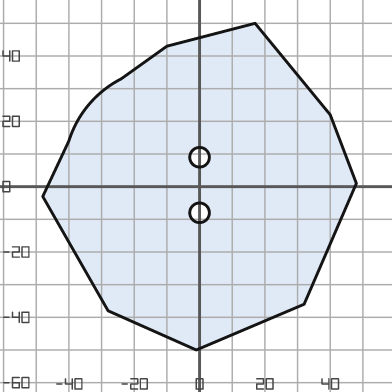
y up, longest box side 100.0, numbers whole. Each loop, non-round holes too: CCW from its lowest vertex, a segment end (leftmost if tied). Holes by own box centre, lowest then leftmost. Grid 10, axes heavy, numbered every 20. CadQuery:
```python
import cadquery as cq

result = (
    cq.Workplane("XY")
    .moveTo(-1.0, -50.0)
    .lineTo(32.0, -36.0)
    .lineTo(48.0, 1.0)
    .lineTo(40.0, 22.0)
    .lineTo(17.0, 50.0)
    .lineTo(-10.0, 43.0)
    .lineTo(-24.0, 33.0)
    .threePointArc((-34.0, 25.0), (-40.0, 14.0))
    .lineTo(-48.0, -3.0)
    .lineTo(-28.0, -38.0)
    .close()
    .moveTo(0.0, -8.0)
    .circle(3.0)
    .moveTo(0.0, 9.0)
    .circle(3.0)
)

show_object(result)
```